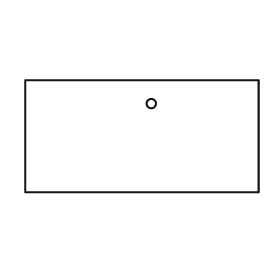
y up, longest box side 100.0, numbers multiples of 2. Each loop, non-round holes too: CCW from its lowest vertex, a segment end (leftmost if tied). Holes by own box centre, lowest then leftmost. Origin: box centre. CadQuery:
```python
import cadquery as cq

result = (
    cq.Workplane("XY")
    .moveTo(-50.0, -24.0)
    .lineTo(50.0, -24.0)
    .lineTo(50.0, 24.0)
    .lineTo(-50.0, 24.0)
    .close()
    .moveTo(4.0, 14.0)
    .circle(2.0)
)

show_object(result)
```